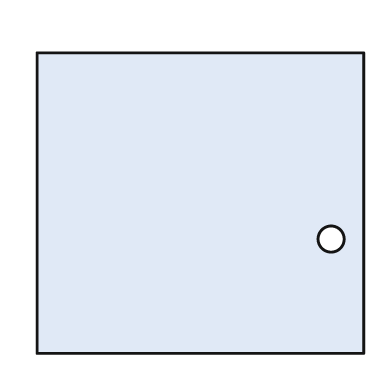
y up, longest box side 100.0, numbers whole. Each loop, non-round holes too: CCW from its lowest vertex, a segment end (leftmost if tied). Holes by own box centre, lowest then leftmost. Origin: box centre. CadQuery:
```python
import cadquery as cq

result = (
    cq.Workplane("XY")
    .moveTo(-50.0, -46.0)
    .lineTo(50.0, -46.0)
    .lineTo(50.0, 46.0)
    .lineTo(-50.0, 46.0)
    .close()
    .moveTo(40.0, -11.0)
    .circle(4.0)
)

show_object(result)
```